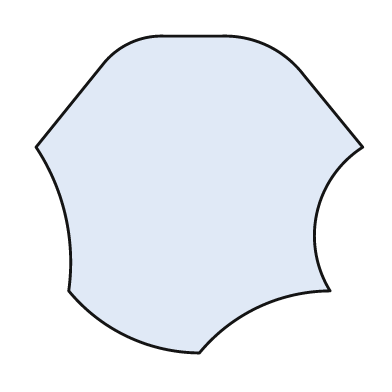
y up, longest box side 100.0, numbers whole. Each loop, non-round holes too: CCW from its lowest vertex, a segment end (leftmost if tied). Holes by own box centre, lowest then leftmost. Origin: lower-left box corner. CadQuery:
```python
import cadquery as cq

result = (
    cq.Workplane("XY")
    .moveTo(50.0, 0.0)
    .threePointArc((68.0, 14.0), (90.0, 19.0))
    .threePointArc((86.0, 43.0), (100.0, 63.0))
    .lineTo(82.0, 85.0)
    .threePointArc((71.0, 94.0), (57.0, 97.0))
    .lineTo(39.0, 97.0)
    .threePointArc((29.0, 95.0), (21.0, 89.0))
    .lineTo(0.0, 63.0)
    .threePointArc((9.0, 42.0), (10.0, 19.0))
    .threePointArc((28.0, 5.0), (50.0, 0.0))
    .close()
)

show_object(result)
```